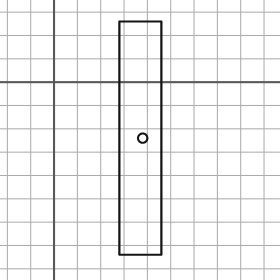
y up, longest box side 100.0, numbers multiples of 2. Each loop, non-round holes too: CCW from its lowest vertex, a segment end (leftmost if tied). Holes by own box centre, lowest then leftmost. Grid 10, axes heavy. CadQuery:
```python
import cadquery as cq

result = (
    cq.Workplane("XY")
    .moveTo(28.0, -74.0)
    .lineTo(46.0, -74.0)
    .lineTo(46.0, 26.0)
    .lineTo(28.0, 26.0)
    .close()
    .moveTo(38.0, -24.0)
    .circle(2.0)
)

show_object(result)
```